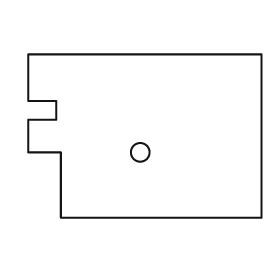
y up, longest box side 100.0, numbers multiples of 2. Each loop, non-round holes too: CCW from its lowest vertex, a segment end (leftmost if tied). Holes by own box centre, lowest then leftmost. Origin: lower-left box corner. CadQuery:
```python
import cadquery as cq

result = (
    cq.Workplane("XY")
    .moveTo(14.0, 0.0)
    .lineTo(100.0, 0.0)
    .lineTo(100.0, 70.0)
    .lineTo(0.0, 70.0)
    .lineTo(0.0, 50.0)
    .lineTo(12.0, 50.0)
    .lineTo(12.0, 42.0)
    .lineTo(0.0, 42.0)
    .lineTo(0.0, 28.0)
    .lineTo(14.0, 28.0)
    .close()
    .moveTo(48.0, 28.0)
    .circle(4.0)
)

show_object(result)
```